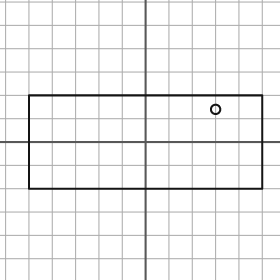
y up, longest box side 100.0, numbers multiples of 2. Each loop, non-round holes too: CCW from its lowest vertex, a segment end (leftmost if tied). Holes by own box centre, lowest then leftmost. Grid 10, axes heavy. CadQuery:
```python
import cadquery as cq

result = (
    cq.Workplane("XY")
    .moveTo(-50.0, -20.0)
    .lineTo(50.0, -20.0)
    .lineTo(50.0, 20.0)
    .lineTo(-50.0, 20.0)
    .close()
    .moveTo(30.0, 14.0)
    .circle(2.0)
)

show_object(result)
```